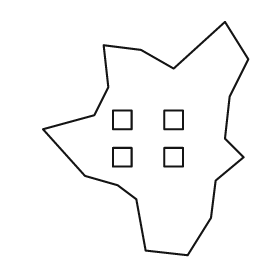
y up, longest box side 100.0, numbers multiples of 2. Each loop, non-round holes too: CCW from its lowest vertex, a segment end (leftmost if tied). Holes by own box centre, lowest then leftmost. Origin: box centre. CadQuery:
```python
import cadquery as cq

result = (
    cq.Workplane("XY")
    .moveTo(18.0, -50.0)
    .lineTo(28.0, -34.0)
    .lineTo(30.0, -18.0)
    .lineTo(42.0, -8.0)
    .lineTo(34.0, 0.0)
    .lineTo(36.0, 18.0)
    .lineTo(44.0, 34.0)
    .lineTo(34.0, 50.0)
    .lineTo(12.0, 30.0)
    .lineTo(-2.0, 38.0)
    .lineTo(-18.0, 40.0)
    .lineTo(-16.0, 22.0)
    .lineTo(-22.0, 10.0)
    .lineTo(-44.0, 4.0)
    .lineTo(-26.0, -16.0)
    .lineTo(-12.0, -20.0)
    .lineTo(-4.0, -26.0)
    .lineTo(0.0, -48.0)
    .close()
    .moveTo(-14.0, -12.0)
    .lineTo(-6.0, -12.0)
    .lineTo(-6.0, -4.0)
    .lineTo(-14.0, -4.0)
    .close()
    .moveTo(8.0, -12.0)
    .lineTo(16.0, -12.0)
    .lineTo(16.0, -4.0)
    .lineTo(8.0, -4.0)
    .close()
    .moveTo(-14.0, 4.0)
    .lineTo(-6.0, 4.0)
    .lineTo(-6.0, 12.0)
    .lineTo(-14.0, 12.0)
    .close()
    .moveTo(8.0, 4.0)
    .lineTo(16.0, 4.0)
    .lineTo(16.0, 12.0)
    .lineTo(8.0, 12.0)
    .close()
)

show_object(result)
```